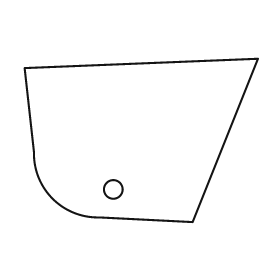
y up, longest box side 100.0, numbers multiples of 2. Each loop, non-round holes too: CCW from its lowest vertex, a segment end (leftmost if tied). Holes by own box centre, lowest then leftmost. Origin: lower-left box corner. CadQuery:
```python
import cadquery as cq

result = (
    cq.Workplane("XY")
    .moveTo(72.0, 0.0)
    .lineTo(100.0, 70.0)
    .lineTo(0.0, 66.0)
    .lineTo(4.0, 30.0)
    .threePointArc((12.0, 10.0), (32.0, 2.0))
    .close()
    .moveTo(38.0, 14.0)
    .circle(4.0)
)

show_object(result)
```